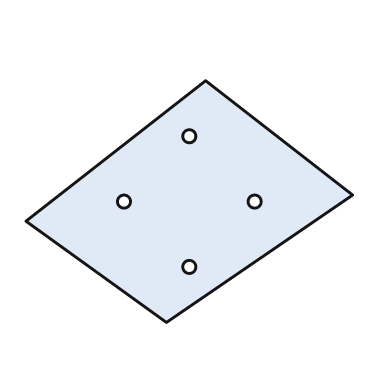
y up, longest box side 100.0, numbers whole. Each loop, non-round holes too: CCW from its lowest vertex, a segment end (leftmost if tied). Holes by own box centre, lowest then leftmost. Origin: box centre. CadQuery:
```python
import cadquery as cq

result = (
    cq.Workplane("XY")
    .moveTo(-7.0, -37.0)
    .lineTo(50.0, 2.0)
    .lineTo(5.0, 37.0)
    .lineTo(-50.0, -6.0)
    .close()
    .moveTo(0.0, -20.0)
    .circle(2.0)
    .moveTo(-20.0, 0.0)
    .circle(2.0)
    .moveTo(20.0, 0.0)
    .circle(2.0)
    .moveTo(0.0, 20.0)
    .circle(2.0)
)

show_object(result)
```